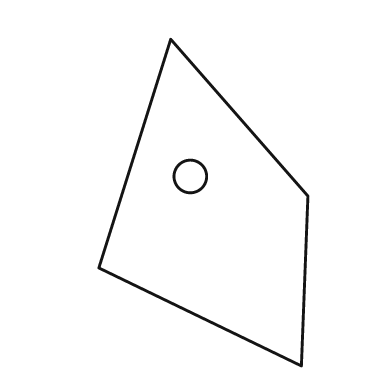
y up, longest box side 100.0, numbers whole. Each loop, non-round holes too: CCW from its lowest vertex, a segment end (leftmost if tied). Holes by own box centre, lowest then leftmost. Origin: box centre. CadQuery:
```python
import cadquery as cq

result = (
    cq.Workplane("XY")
    .moveTo(30.0, -50.0)
    .lineTo(32.0, 2.0)
    .lineTo(-10.0, 50.0)
    .lineTo(-32.0, -20.0)
    .close()
    .moveTo(-4.0, 8.0)
    .circle(5.0)
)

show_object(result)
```